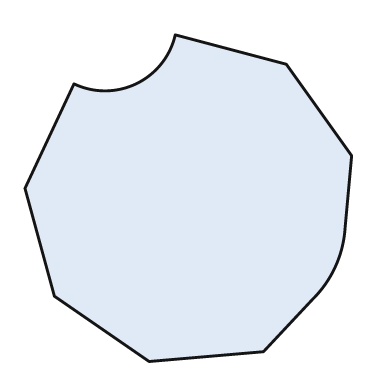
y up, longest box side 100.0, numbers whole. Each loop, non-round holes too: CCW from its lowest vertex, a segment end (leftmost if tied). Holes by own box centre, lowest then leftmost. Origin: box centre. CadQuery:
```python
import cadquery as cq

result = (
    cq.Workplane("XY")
    .moveTo(-12.0, -50.0)
    .lineTo(23.0, -47.0)
    .lineTo(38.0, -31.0)
    .threePointArc((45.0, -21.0), (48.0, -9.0))
    .lineTo(50.0, 13.0)
    .lineTo(30.0, 41.0)
    .lineTo(-4.0, 50.0)
    .threePointArc((-16.0, 35.0), (-35.0, 35.0))
    .lineTo(-50.0, 3.0)
    .lineTo(-41.0, -30.0)
    .close()
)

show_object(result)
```